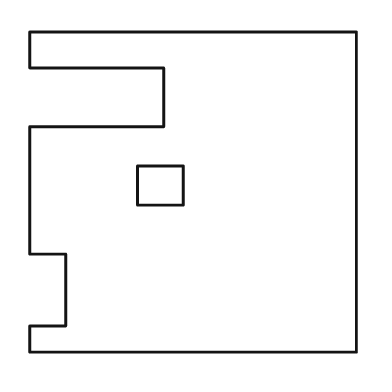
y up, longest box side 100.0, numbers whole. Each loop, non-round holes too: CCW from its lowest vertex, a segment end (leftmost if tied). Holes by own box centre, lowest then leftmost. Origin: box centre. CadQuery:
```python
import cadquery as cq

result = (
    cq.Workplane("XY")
    .moveTo(-50.0, -49.0)
    .lineTo(50.0, -49.0)
    .lineTo(50.0, 49.0)
    .lineTo(-50.0, 49.0)
    .lineTo(-50.0, 38.0)
    .lineTo(-9.0, 38.0)
    .lineTo(-9.0, 20.0)
    .lineTo(-50.0, 20.0)
    .lineTo(-50.0, -19.0)
    .lineTo(-39.0, -19.0)
    .lineTo(-39.0, -41.0)
    .lineTo(-50.0, -41.0)
    .close()
    .moveTo(-17.0, -4.0)
    .lineTo(-3.0, -4.0)
    .lineTo(-3.0, 8.0)
    .lineTo(-17.0, 8.0)
    .close()
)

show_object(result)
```